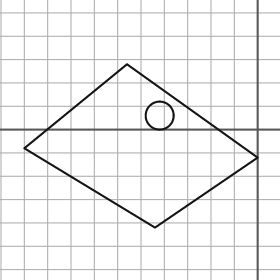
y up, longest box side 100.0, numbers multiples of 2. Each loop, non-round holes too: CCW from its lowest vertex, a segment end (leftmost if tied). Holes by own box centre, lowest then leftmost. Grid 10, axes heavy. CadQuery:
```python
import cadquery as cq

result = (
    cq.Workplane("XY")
    .moveTo(-44.0, -42.0)
    .lineTo(0.0, -12.0)
    .lineTo(-56.0, 28.0)
    .lineTo(-100.0, -8.0)
    .close()
    .moveTo(-42.0, 6.0)
    .circle(6.0)
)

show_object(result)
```